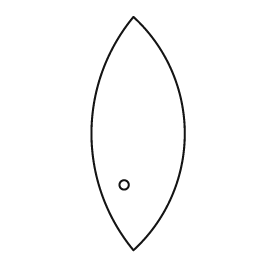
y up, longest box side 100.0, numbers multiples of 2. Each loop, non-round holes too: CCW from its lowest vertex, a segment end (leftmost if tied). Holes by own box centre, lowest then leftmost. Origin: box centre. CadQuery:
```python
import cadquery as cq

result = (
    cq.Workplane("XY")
    .moveTo(-2.0, -50.0)
    .threePointArc((20.0, 0.0), (-2.0, 50.0))
    .threePointArc((-20.0, 0.0), (-2.0, -50.0))
    .close()
    .moveTo(-6.0, -22.0)
    .circle(2.0)
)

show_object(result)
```